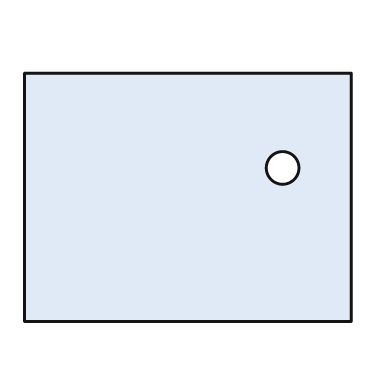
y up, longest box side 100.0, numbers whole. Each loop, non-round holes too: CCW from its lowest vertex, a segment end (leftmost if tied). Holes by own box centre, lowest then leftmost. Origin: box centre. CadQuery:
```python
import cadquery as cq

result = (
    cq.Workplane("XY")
    .moveTo(-50.0, -38.0)
    .lineTo(50.0, -38.0)
    .lineTo(50.0, 38.0)
    .lineTo(-50.0, 38.0)
    .close()
    .moveTo(29.0, 9.0)
    .circle(5.0)
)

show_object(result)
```